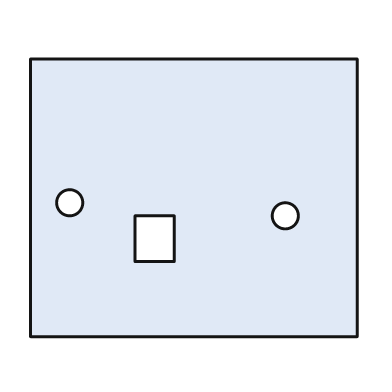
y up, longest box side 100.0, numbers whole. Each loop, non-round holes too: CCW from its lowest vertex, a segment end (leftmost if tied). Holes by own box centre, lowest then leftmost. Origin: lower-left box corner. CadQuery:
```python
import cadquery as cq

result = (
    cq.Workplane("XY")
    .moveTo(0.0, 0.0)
    .lineTo(100.0, 0.0)
    .lineTo(100.0, 85.0)
    .lineTo(0.0, 85.0)
    .close()
    .moveTo(32.0, 23.0)
    .lineTo(44.0, 23.0)
    .lineTo(44.0, 37.0)
    .lineTo(32.0, 37.0)
    .close()
    .moveTo(78.0, 37.0)
    .circle(4.0)
    .moveTo(12.0, 41.0)
    .circle(4.0)
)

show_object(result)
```